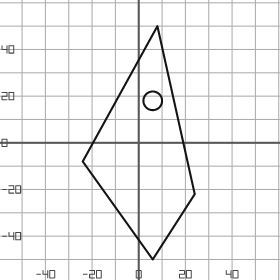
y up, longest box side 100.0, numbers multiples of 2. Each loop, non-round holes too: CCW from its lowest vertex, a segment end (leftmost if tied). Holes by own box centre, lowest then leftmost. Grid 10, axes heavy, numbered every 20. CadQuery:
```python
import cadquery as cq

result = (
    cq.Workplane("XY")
    .moveTo(6.0, -50.0)
    .lineTo(24.0, -22.0)
    .lineTo(8.0, 50.0)
    .lineTo(-24.0, -8.0)
    .close()
    .moveTo(6.0, 18.0)
    .circle(4.0)
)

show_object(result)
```